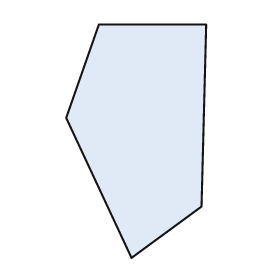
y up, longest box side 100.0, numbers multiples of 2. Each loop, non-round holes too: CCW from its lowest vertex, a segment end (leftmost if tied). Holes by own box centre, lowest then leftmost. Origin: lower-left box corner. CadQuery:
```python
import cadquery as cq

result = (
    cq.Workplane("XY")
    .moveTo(28.0, 0.0)
    .lineTo(58.0, 22.0)
    .lineTo(60.0, 100.0)
    .lineTo(14.0, 100.0)
    .lineTo(0.0, 60.0)
    .close()
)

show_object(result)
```